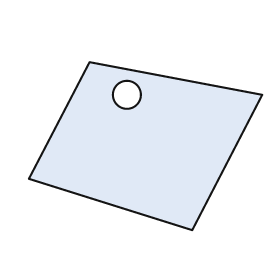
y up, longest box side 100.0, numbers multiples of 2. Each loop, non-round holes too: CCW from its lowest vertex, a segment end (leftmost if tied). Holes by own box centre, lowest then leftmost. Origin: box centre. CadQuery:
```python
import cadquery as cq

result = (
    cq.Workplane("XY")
    .moveTo(20.0, -36.0)
    .lineTo(50.0, 22.0)
    .lineTo(-24.0, 36.0)
    .lineTo(-50.0, -14.0)
    .close()
    .moveTo(-8.0, 22.0)
    .circle(6.0)
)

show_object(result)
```